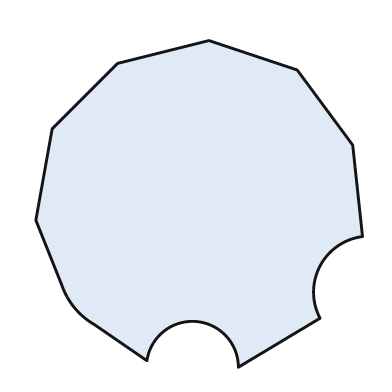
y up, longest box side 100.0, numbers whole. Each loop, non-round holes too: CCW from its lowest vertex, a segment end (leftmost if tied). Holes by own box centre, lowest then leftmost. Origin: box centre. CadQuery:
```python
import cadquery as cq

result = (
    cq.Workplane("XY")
    .moveTo(12.0, -50.0)
    .lineTo(37.0, -35.0)
    .threePointArc((37.0, -19.0), (50.0, -10.0))
    .lineTo(47.0, 18.0)
    .lineTo(30.0, 41.0)
    .lineTo(3.0, 50.0)
    .lineTo(-25.0, 43.0)
    .lineTo(-45.0, 23.0)
    .lineTo(-50.0, -5.0)
    .lineTo(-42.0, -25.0)
    .threePointArc((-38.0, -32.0), (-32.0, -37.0))
    .lineTo(-16.0, -48.0)
    .threePointArc((-1.0, -36.0), (12.0, -50.0))
    .close()
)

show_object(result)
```